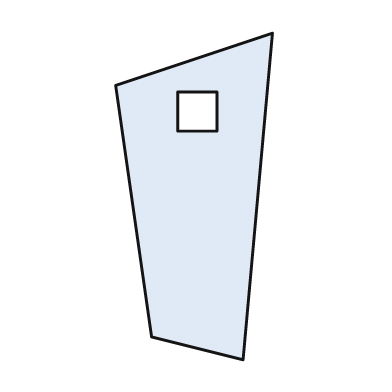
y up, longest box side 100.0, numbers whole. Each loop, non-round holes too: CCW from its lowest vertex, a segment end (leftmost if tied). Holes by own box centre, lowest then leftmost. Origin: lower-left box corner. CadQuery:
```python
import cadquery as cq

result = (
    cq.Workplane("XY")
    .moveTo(39.0, 0.0)
    .lineTo(48.0, 100.0)
    .lineTo(0.0, 84.0)
    .lineTo(11.0, 7.0)
    .close()
    .moveTo(19.0, 70.0)
    .lineTo(31.0, 70.0)
    .lineTo(31.0, 82.0)
    .lineTo(19.0, 82.0)
    .close()
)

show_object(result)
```